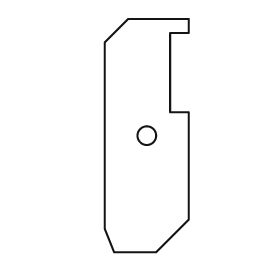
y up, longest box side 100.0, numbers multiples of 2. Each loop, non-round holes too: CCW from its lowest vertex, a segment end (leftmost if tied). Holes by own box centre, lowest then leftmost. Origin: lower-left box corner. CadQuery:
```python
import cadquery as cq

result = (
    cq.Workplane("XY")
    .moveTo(4.0, 0.0)
    .lineTo(22.0, 0.0)
    .lineTo(36.0, 14.0)
    .lineTo(36.0, 60.0)
    .lineTo(28.0, 60.0)
    .lineTo(28.0, 94.0)
    .lineTo(36.0, 94.0)
    .lineTo(36.0, 100.0)
    .lineTo(10.0, 100.0)
    .lineTo(0.0, 90.0)
    .lineTo(0.0, 10.0)
    .close()
    .moveTo(18.0, 50.0)
    .circle(4.0)
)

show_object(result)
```